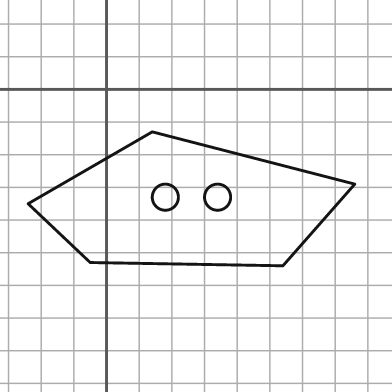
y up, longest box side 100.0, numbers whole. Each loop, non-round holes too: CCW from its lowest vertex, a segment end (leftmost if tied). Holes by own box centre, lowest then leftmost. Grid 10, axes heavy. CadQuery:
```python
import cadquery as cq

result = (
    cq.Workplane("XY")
    .moveTo(54.0, -54.0)
    .lineTo(76.0, -29.0)
    .lineTo(14.0, -13.0)
    .lineTo(-24.0, -35.0)
    .lineTo(-5.0, -53.0)
    .close()
    .moveTo(18.0, -33.0)
    .circle(4.0)
    .moveTo(34.0, -33.0)
    .circle(4.0)
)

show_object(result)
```